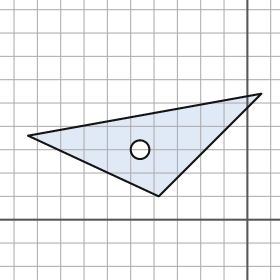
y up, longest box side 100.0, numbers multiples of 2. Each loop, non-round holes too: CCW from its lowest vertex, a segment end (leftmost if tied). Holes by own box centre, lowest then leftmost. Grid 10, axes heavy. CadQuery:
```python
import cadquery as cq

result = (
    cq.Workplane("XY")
    .moveTo(-38.0, 10.0)
    .lineTo(6.0, 54.0)
    .lineTo(-94.0, 36.0)
    .close()
    .moveTo(-46.0, 30.0)
    .circle(4.0)
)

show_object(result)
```